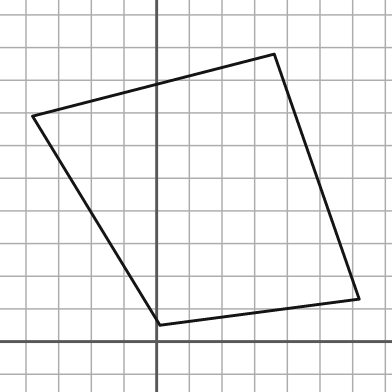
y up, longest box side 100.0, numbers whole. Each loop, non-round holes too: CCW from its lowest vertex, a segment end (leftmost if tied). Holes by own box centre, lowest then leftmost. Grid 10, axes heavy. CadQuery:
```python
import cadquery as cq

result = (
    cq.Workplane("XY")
    .moveTo(1.0, 5.0)
    .lineTo(62.0, 13.0)
    .lineTo(36.0, 88.0)
    .lineTo(-38.0, 69.0)
    .close()
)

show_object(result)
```